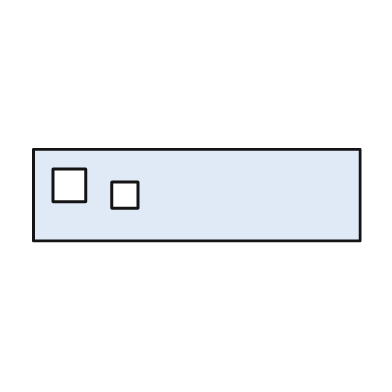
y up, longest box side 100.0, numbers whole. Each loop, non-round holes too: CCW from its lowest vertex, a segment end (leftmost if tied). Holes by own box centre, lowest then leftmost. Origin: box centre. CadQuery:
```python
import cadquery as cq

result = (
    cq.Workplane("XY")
    .moveTo(-50.0, -14.0)
    .lineTo(50.0, -14.0)
    .lineTo(50.0, 14.0)
    .lineTo(-50.0, 14.0)
    .close()
    .moveTo(-26.0, -4.0)
    .lineTo(-18.0, -4.0)
    .lineTo(-18.0, 4.0)
    .lineTo(-26.0, 4.0)
    .close()
    .moveTo(-44.0, -2.0)
    .lineTo(-34.0, -2.0)
    .lineTo(-34.0, 8.0)
    .lineTo(-44.0, 8.0)
    .close()
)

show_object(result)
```